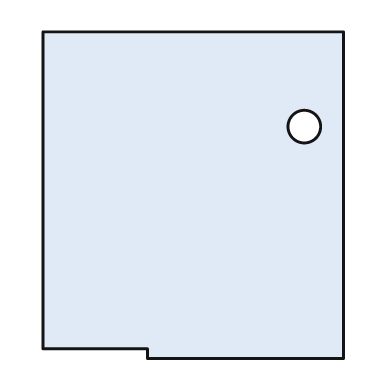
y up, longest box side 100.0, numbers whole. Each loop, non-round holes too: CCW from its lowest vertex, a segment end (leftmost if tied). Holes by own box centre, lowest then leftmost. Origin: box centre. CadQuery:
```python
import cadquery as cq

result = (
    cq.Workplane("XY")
    .moveTo(-14.0, -50.0)
    .lineTo(46.0, -50.0)
    .lineTo(46.0, 50.0)
    .lineTo(-46.0, 50.0)
    .lineTo(-46.0, -47.0)
    .lineTo(-14.0, -47.0)
    .close()
    .moveTo(34.0, 21.0)
    .circle(5.0)
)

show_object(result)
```